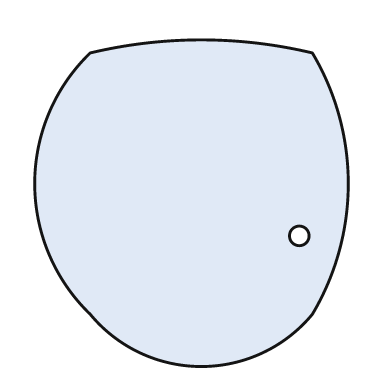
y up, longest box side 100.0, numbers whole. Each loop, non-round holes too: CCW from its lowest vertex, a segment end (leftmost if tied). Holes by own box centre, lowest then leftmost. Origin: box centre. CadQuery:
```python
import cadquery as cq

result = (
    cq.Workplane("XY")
    .moveTo(-31.0, -34.0)
    .threePointArc((3.0, -50.0), (37.0, -34.0))
    .threePointArc((48.0, 6.0), (37.0, 46.0))
    .threePointArc((3.0, 50.0), (-31.0, 46.0))
    .threePointArc((-48.0, 6.0), (-31.0, -34.0))
    .close()
    .moveTo(33.0, -10.0)
    .circle(3.0)
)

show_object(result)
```